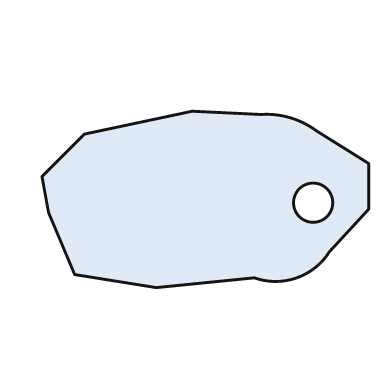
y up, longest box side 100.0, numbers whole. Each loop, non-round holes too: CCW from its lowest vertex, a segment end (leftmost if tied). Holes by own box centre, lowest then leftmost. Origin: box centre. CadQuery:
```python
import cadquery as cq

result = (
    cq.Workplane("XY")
    .moveTo(-15.0, -27.0)
    .lineTo(15.0, -24.0)
    .threePointArc((28.0, -24.0), (38.0, -16.0))
    .lineTo(50.0, -3.0)
    .lineTo(50.0, 11.0)
    .lineTo(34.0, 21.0)
    .threePointArc((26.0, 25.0), (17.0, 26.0))
    .lineTo(-4.0, 27.0)
    .lineTo(-37.0, 20.0)
    .lineTo(-50.0, 7.0)
    .lineTo(-48.0, -4.0)
    .lineTo(-40.0, -23.0)
    .close()
    .moveTo(33.0, -1.0)
    .circle(6.0)
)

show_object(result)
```